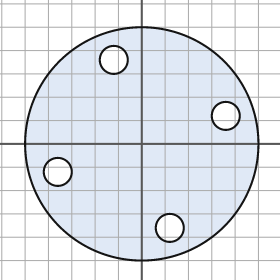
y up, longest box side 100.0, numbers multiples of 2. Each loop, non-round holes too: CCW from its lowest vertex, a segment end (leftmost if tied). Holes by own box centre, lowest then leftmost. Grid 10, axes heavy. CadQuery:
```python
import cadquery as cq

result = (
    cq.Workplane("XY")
    .moveTo(0.0, 0.0)
    .circle(50.0)
    .moveTo(12.0, -36.0)
    .circle(6.0)
    .moveTo(-36.0, -12.0)
    .circle(6.0)
    .moveTo(36.0, 12.0)
    .circle(6.0)
    .moveTo(-12.0, 36.0)
    .circle(6.0)
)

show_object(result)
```